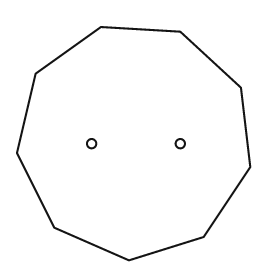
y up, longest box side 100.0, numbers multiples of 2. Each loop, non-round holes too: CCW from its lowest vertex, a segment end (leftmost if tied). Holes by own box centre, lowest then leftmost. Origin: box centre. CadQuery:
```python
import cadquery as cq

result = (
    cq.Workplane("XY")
    .moveTo(-2.0, -50.0)
    .lineTo(30.0, -40.0)
    .lineTo(50.0, -10.0)
    .lineTo(46.0, 24.0)
    .lineTo(20.0, 48.0)
    .lineTo(-14.0, 50.0)
    .lineTo(-42.0, 30.0)
    .lineTo(-50.0, -4.0)
    .lineTo(-34.0, -36.0)
    .close()
    .moveTo(-18.0, 0.0)
    .circle(2.0)
    .moveTo(20.0, 0.0)
    .circle(2.0)
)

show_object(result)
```